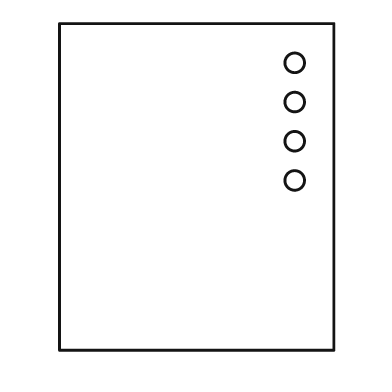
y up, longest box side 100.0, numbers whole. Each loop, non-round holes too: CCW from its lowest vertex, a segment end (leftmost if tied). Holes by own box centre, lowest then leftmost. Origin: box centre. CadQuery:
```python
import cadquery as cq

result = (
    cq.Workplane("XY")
    .moveTo(-42.0, -50.0)
    .lineTo(42.0, -50.0)
    .lineTo(42.0, 50.0)
    .lineTo(-42.0, 50.0)
    .close()
    .moveTo(30.0, 2.0)
    .circle(3.0)
    .moveTo(30.0, 14.0)
    .circle(3.0)
    .moveTo(30.0, 26.0)
    .circle(3.0)
    .moveTo(30.0, 38.0)
    .circle(3.0)
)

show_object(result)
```